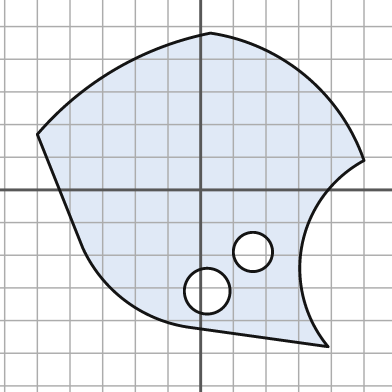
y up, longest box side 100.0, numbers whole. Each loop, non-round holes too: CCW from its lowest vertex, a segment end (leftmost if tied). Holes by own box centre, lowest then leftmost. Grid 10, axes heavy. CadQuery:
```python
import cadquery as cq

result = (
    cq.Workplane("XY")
    .moveTo(39.0, -48.0)
    .threePointArc((31.0, -17.0), (50.0, 9.0))
    .threePointArc((32.0, 35.0), (3.0, 48.0))
    .threePointArc((-26.0, 37.0), (-50.0, 17.0))
    .lineTo(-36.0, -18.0)
    .threePointArc((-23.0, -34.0), (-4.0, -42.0))
    .close()
    .moveTo(2.0, -31.0)
    .circle(7.0)
    .moveTo(16.0, -19.0)
    .circle(6.0)
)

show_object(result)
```